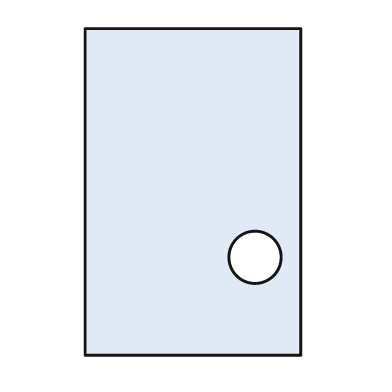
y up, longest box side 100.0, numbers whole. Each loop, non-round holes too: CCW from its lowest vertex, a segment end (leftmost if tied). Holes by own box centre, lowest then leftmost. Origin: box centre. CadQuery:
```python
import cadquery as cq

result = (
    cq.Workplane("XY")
    .moveTo(-33.0, -50.0)
    .lineTo(33.0, -50.0)
    .lineTo(33.0, 50.0)
    .lineTo(-33.0, 50.0)
    .close()
    .moveTo(19.0, -20.0)
    .circle(8.0)
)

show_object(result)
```